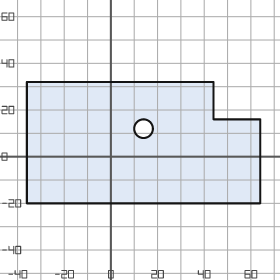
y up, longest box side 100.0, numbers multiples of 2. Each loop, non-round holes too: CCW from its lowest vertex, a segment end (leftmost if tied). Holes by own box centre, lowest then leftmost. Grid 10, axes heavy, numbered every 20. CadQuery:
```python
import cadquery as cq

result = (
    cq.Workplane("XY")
    .moveTo(-36.0, -20.0)
    .lineTo(64.0, -20.0)
    .lineTo(64.0, 16.0)
    .lineTo(44.0, 16.0)
    .lineTo(44.0, 32.0)
    .lineTo(-36.0, 32.0)
    .close()
    .moveTo(14.0, 12.0)
    .circle(4.0)
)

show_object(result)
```